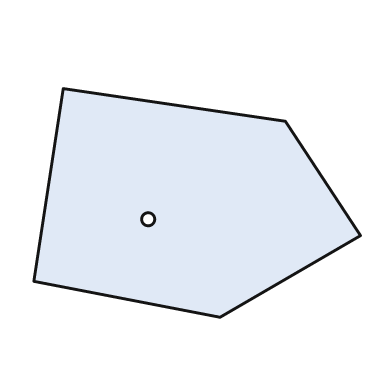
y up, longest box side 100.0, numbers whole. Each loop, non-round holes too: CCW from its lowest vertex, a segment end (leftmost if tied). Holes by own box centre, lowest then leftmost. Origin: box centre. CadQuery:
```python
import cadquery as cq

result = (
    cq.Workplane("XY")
    .moveTo(7.0, -35.0)
    .lineTo(50.0, -10.0)
    .lineTo(27.0, 25.0)
    .lineTo(-41.0, 35.0)
    .lineTo(-50.0, -24.0)
    .close()
    .moveTo(-15.0, -5.0)
    .circle(2.0)
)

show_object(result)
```